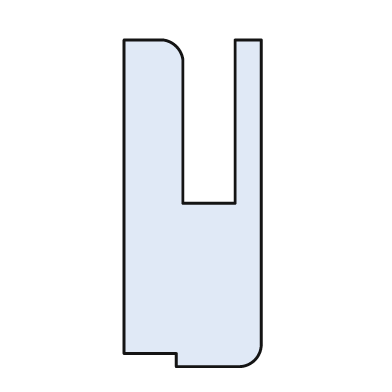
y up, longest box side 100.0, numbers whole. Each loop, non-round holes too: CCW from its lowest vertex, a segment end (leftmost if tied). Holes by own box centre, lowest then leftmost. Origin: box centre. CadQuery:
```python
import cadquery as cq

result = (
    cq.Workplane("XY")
    .moveTo(-5.0, -50.0)
    .lineTo(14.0, -50.0)
    .threePointArc((19.0, -48.0), (21.0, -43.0))
    .lineTo(21.0, 50.0)
    .lineTo(13.0, 50.0)
    .lineTo(13.0, 0.0)
    .lineTo(-3.0, 0.0)
    .lineTo(-3.0, 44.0)
    .threePointArc((-5.0, 48.0), (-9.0, 50.0))
    .lineTo(-21.0, 50.0)
    .lineTo(-21.0, -46.0)
    .lineTo(-5.0, -46.0)
    .close()
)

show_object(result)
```